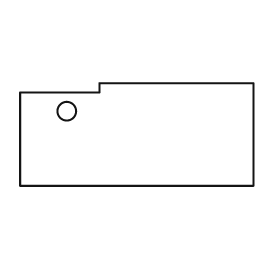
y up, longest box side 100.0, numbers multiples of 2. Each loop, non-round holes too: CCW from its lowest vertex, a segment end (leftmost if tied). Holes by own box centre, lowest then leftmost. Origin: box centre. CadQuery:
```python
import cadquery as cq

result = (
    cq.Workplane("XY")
    .moveTo(-50.0, -22.0)
    .lineTo(50.0, -22.0)
    .lineTo(50.0, 22.0)
    .lineTo(-16.0, 22.0)
    .lineTo(-16.0, 18.0)
    .lineTo(-50.0, 18.0)
    .close()
    .moveTo(-30.0, 10.0)
    .circle(4.0)
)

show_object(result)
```